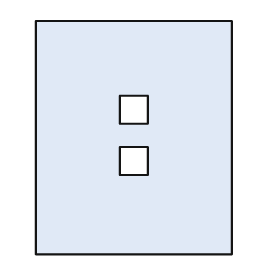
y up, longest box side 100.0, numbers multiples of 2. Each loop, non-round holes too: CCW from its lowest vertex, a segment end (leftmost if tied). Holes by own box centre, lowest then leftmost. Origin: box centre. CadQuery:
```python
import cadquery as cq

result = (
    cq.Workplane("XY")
    .moveTo(-42.0, -50.0)
    .lineTo(42.0, -50.0)
    .lineTo(42.0, 50.0)
    .lineTo(-42.0, 50.0)
    .close()
    .moveTo(-6.0, -16.0)
    .lineTo(6.0, -16.0)
    .lineTo(6.0, -4.0)
    .lineTo(-6.0, -4.0)
    .close()
    .moveTo(-6.0, 6.0)
    .lineTo(6.0, 6.0)
    .lineTo(6.0, 18.0)
    .lineTo(-6.0, 18.0)
    .close()
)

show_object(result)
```